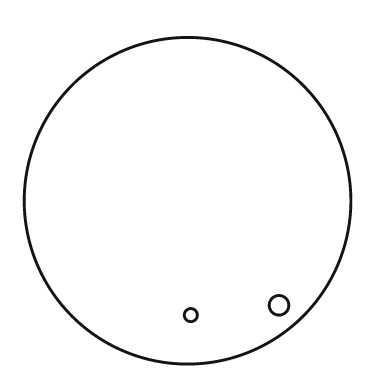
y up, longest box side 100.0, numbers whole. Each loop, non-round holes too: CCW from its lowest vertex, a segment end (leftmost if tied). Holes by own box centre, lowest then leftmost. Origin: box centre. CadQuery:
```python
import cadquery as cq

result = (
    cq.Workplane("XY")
    .moveTo(0.0, 0.0)
    .circle(50.0)
    .moveTo(1.0, -35.0)
    .circle(2.0)
    .moveTo(28.0, -32.0)
    .circle(3.0)
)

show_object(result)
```